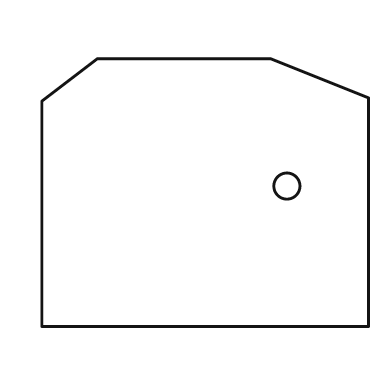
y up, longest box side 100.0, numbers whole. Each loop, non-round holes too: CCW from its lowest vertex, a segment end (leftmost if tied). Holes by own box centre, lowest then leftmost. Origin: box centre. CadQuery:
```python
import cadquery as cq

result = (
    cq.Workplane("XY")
    .moveTo(-50.0, -41.0)
    .lineTo(50.0, -41.0)
    .lineTo(50.0, 29.0)
    .lineTo(20.0, 41.0)
    .lineTo(-33.0, 41.0)
    .lineTo(-50.0, 28.0)
    .close()
    .moveTo(25.0, 2.0)
    .circle(4.0)
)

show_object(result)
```